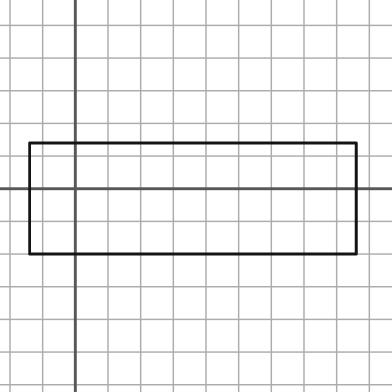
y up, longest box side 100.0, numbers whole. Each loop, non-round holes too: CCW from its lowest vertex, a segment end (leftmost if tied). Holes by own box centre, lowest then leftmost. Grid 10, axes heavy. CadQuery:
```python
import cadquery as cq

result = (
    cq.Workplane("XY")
    .moveTo(-14.0, -20.0)
    .lineTo(86.0, -20.0)
    .lineTo(86.0, 14.0)
    .lineTo(-14.0, 14.0)
    .close()
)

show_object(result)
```